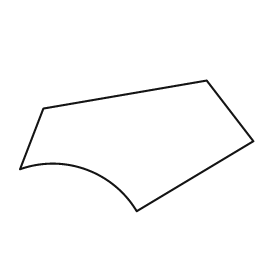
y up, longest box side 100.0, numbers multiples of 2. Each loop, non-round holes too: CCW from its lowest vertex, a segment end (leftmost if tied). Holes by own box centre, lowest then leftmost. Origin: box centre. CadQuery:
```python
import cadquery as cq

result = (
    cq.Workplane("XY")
    .moveTo(0.0, -28.0)
    .lineTo(50.0, 2.0)
    .lineTo(30.0, 28.0)
    .lineTo(-40.0, 16.0)
    .lineTo(-50.0, -10.0)
    .threePointArc((-22.0, -10.0), (0.0, -28.0))
    .close()
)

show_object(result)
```